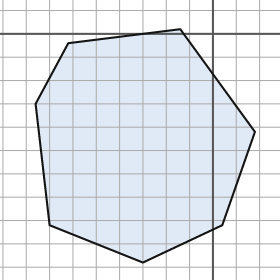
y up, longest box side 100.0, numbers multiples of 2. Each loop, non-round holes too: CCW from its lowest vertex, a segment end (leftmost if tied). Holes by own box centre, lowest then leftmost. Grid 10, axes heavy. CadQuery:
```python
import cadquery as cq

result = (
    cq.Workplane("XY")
    .moveTo(-30.0, -98.0)
    .lineTo(4.0, -82.0)
    .lineTo(18.0, -42.0)
    .lineTo(-14.0, 2.0)
    .lineTo(-62.0, -4.0)
    .lineTo(-76.0, -30.0)
    .lineTo(-70.0, -82.0)
    .close()
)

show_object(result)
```